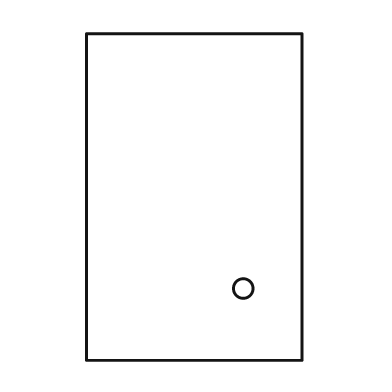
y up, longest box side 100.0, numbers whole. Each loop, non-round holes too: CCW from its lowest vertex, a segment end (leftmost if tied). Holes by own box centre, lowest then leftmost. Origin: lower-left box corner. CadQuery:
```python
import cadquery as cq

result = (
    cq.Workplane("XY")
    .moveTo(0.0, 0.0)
    .lineTo(66.0, 0.0)
    .lineTo(66.0, 100.0)
    .lineTo(0.0, 100.0)
    .close()
    .moveTo(48.0, 22.0)
    .circle(3.0)
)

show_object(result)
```